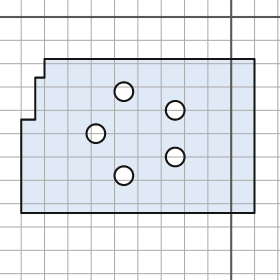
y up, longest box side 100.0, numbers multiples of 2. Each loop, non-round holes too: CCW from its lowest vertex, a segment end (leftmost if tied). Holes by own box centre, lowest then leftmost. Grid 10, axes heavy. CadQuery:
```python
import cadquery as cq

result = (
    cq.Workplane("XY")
    .moveTo(-90.0, -84.0)
    .lineTo(10.0, -84.0)
    .lineTo(10.0, -18.0)
    .lineTo(-80.0, -18.0)
    .lineTo(-80.0, -26.0)
    .lineTo(-84.0, -26.0)
    .lineTo(-84.0, -44.0)
    .lineTo(-90.0, -44.0)
    .close()
    .moveTo(-46.0, -68.0)
    .circle(4.0)
    .moveTo(-24.0, -60.0)
    .circle(4.0)
    .moveTo(-58.0, -50.0)
    .circle(4.0)
    .moveTo(-24.0, -40.0)
    .circle(4.0)
    .moveTo(-46.0, -32.0)
    .circle(4.0)
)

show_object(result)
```